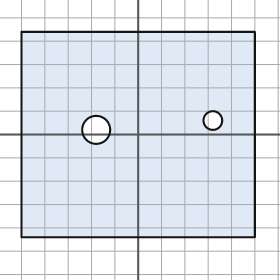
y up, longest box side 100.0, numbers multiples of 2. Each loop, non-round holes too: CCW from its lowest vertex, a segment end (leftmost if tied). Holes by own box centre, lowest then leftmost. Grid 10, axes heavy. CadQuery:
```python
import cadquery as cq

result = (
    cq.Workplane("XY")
    .moveTo(-50.0, -44.0)
    .lineTo(50.0, -44.0)
    .lineTo(50.0, 44.0)
    .lineTo(-50.0, 44.0)
    .close()
    .moveTo(-18.0, 2.0)
    .circle(6.0)
    .moveTo(32.0, 6.0)
    .circle(4.0)
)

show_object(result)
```